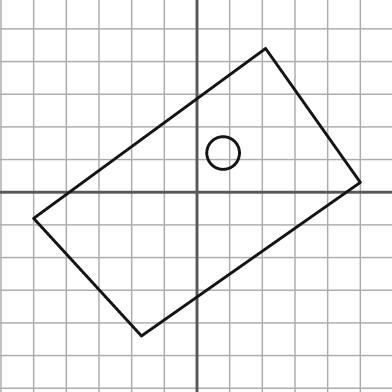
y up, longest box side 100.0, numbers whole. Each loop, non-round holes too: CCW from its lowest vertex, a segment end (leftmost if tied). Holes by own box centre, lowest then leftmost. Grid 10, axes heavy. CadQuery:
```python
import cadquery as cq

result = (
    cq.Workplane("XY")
    .moveTo(-17.0, -44.0)
    .lineTo(50.0, 3.0)
    .lineTo(21.0, 44.0)
    .lineTo(-50.0, -8.0)
    .close()
    .moveTo(8.0, 12.0)
    .circle(5.0)
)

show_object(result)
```